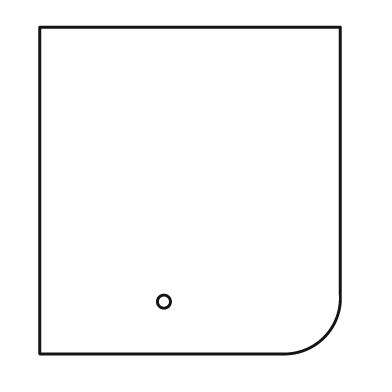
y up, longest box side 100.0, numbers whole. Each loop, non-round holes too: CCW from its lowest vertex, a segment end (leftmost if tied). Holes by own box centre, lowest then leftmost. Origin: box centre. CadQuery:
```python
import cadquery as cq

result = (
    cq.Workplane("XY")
    .moveTo(-46.0, -50.0)
    .lineTo(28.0, -50.0)
    .threePointArc((41.0, -45.0), (46.0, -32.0))
    .lineTo(46.0, 50.0)
    .lineTo(-46.0, 50.0)
    .close()
    .moveTo(-8.0, -34.0)
    .circle(2.0)
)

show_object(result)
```